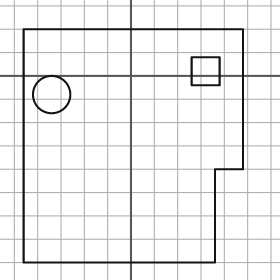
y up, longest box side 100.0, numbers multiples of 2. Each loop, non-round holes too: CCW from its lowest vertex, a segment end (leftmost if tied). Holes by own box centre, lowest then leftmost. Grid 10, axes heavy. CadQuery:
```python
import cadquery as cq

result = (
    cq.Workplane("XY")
    .moveTo(-46.0, -80.0)
    .lineTo(36.0, -80.0)
    .lineTo(36.0, -40.0)
    .lineTo(48.0, -40.0)
    .lineTo(48.0, 20.0)
    .lineTo(-46.0, 20.0)
    .close()
    .moveTo(-34.0, -8.0)
    .circle(8.0)
    .moveTo(26.0, -4.0)
    .lineTo(38.0, -4.0)
    .lineTo(38.0, 8.0)
    .lineTo(26.0, 8.0)
    .close()
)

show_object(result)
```